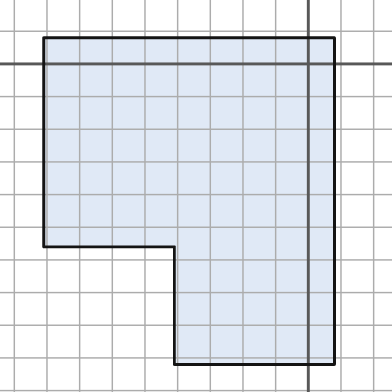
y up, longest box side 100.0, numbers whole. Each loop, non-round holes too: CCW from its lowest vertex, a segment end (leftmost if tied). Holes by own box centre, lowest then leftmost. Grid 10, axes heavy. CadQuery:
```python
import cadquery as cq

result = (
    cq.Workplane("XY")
    .moveTo(-41.0, -92.0)
    .lineTo(8.0, -92.0)
    .lineTo(8.0, 8.0)
    .lineTo(-81.0, 8.0)
    .lineTo(-81.0, -56.0)
    .lineTo(-41.0, -56.0)
    .close()
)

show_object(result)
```